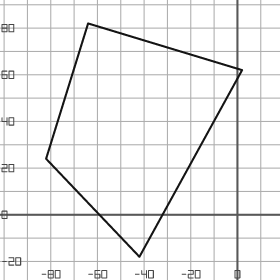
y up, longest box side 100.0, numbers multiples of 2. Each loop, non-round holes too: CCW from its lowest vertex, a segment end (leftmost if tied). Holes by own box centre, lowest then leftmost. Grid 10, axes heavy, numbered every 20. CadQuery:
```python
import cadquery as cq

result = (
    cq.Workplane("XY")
    .moveTo(-42.0, -18.0)
    .lineTo(2.0, 62.0)
    .lineTo(-64.0, 82.0)
    .lineTo(-82.0, 24.0)
    .close()
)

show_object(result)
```